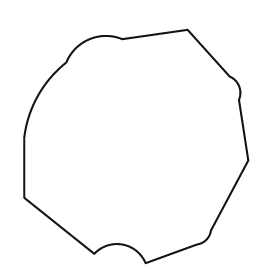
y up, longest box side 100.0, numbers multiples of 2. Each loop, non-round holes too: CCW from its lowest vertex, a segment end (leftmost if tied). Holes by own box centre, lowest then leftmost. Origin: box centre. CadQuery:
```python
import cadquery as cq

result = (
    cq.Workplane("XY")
    .moveTo(4.0, -50.0)
    .lineTo(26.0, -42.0)
    .threePointArc((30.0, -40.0), (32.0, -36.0))
    .lineTo(48.0, -6.0)
    .lineTo(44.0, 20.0)
    .threePointArc((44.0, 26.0), (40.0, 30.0))
    .lineTo(22.0, 50.0)
    .lineTo(-6.0, 46.0)
    .threePointArc((-20.0, 46.0), (-30.0, 36.0))
    .threePointArc((-42.0, 22.0), (-48.0, 4.0))
    .lineTo(-48.0, -22.0)
    .lineTo(-18.0, -46.0)
    .threePointArc((-6.0, -42.0), (4.0, -50.0))
    .close()
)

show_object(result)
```